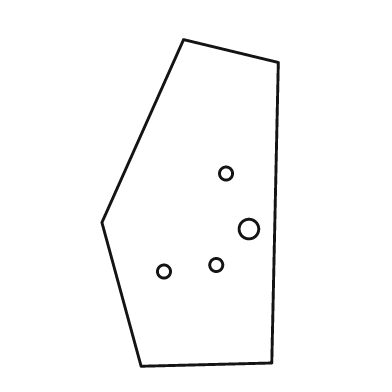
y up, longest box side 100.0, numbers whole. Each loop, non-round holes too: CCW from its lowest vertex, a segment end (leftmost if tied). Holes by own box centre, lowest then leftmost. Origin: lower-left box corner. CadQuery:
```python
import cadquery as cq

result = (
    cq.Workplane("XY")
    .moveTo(12.0, 0.0)
    .lineTo(52.0, 1.0)
    .lineTo(54.0, 93.0)
    .lineTo(25.0, 100.0)
    .lineTo(0.0, 44.0)
    .close()
    .moveTo(19.0, 29.0)
    .circle(2.0)
    .moveTo(35.0, 31.0)
    .circle(2.0)
    .moveTo(45.0, 42.0)
    .circle(3.0)
    .moveTo(38.0, 59.0)
    .circle(2.0)
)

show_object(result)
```